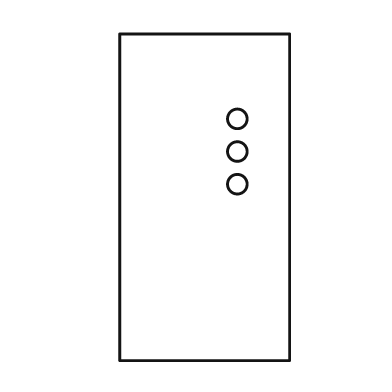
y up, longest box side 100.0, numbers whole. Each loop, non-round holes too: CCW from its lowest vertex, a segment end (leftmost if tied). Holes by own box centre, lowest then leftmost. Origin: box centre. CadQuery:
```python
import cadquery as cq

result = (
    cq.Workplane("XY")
    .moveTo(-26.0, -50.0)
    .lineTo(26.0, -50.0)
    .lineTo(26.0, 50.0)
    .lineTo(-26.0, 50.0)
    .close()
    .moveTo(10.0, 4.0)
    .circle(3.0)
    .moveTo(10.0, 14.0)
    .circle(3.0)
    .moveTo(10.0, 24.0)
    .circle(3.0)
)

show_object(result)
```